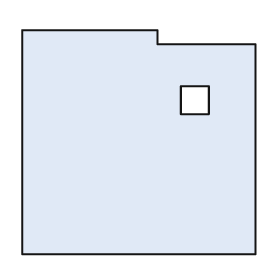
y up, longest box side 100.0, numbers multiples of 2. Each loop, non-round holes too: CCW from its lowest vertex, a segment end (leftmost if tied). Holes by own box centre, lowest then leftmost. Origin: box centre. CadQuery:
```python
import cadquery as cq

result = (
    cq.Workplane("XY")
    .moveTo(-50.0, -48.0)
    .lineTo(50.0, -48.0)
    .lineTo(50.0, 42.0)
    .lineTo(8.0, 42.0)
    .lineTo(8.0, 48.0)
    .lineTo(-50.0, 48.0)
    .close()
    .moveTo(18.0, 12.0)
    .lineTo(30.0, 12.0)
    .lineTo(30.0, 24.0)
    .lineTo(18.0, 24.0)
    .close()
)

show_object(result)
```